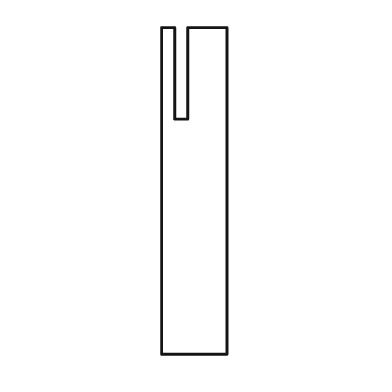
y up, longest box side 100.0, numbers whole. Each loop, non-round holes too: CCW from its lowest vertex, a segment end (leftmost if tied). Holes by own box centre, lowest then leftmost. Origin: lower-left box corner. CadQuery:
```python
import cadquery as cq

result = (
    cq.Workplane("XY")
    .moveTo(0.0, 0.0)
    .lineTo(20.0, 0.0)
    .lineTo(20.0, 100.0)
    .lineTo(8.0, 100.0)
    .lineTo(8.0, 72.0)
    .lineTo(4.0, 72.0)
    .lineTo(4.0, 100.0)
    .lineTo(0.0, 100.0)
    .close()
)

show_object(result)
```